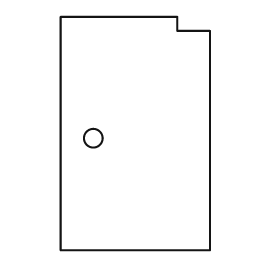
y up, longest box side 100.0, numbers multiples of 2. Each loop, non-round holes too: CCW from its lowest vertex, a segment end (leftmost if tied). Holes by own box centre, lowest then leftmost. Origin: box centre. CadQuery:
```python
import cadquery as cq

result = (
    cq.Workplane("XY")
    .moveTo(-32.0, -50.0)
    .lineTo(32.0, -50.0)
    .lineTo(32.0, 44.0)
    .lineTo(18.0, 44.0)
    .lineTo(18.0, 50.0)
    .lineTo(-32.0, 50.0)
    .close()
    .moveTo(-18.0, -2.0)
    .circle(4.0)
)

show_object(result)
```